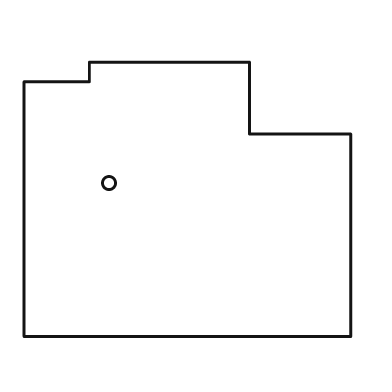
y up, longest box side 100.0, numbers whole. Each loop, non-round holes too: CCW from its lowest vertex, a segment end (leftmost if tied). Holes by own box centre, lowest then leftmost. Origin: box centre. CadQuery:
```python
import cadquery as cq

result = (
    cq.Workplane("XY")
    .moveTo(-50.0, -42.0)
    .lineTo(50.0, -42.0)
    .lineTo(50.0, 20.0)
    .lineTo(19.0, 20.0)
    .lineTo(19.0, 42.0)
    .lineTo(-30.0, 42.0)
    .lineTo(-30.0, 36.0)
    .lineTo(-50.0, 36.0)
    .close()
    .moveTo(-24.0, 5.0)
    .circle(2.0)
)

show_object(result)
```